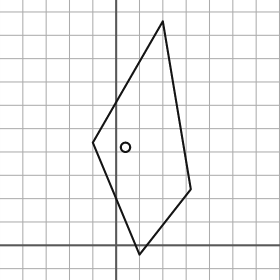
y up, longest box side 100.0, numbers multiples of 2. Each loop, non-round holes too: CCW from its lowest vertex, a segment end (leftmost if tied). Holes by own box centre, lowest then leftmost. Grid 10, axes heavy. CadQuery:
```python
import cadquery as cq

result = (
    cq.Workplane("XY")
    .moveTo(10.0, -4.0)
    .lineTo(32.0, 24.0)
    .lineTo(20.0, 96.0)
    .lineTo(-10.0, 44.0)
    .close()
    .moveTo(4.0, 42.0)
    .circle(2.0)
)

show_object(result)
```